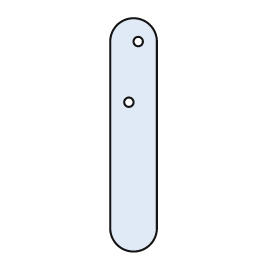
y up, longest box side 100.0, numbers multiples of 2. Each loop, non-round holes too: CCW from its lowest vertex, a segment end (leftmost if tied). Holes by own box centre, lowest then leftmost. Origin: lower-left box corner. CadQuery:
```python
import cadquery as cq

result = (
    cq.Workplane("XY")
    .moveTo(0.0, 10.0)
    .threePointArc((10.0, 0.0), (20.0, 10.0))
    .lineTo(20.0, 90.0)
    .threePointArc((10.0, 100.0), (0.0, 90.0))
    .close()
    .moveTo(8.0, 64.0)
    .circle(2.0)
    .moveTo(12.0, 90.0)
    .circle(2.0)
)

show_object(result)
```